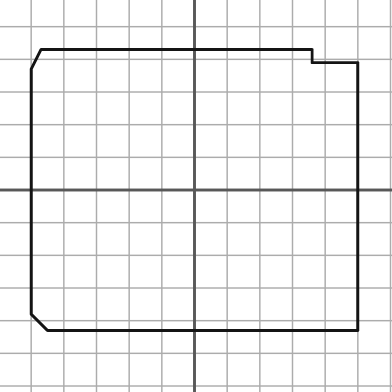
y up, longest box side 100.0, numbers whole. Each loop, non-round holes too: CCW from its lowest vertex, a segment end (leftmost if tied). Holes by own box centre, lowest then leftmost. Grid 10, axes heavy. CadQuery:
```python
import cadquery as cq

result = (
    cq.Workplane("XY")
    .moveTo(-45.0, -43.0)
    .lineTo(50.0, -43.0)
    .lineTo(50.0, 39.0)
    .lineTo(36.0, 39.0)
    .lineTo(36.0, 43.0)
    .lineTo(-47.0, 43.0)
    .lineTo(-50.0, 37.0)
    .lineTo(-50.0, -38.0)
    .close()
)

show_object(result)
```